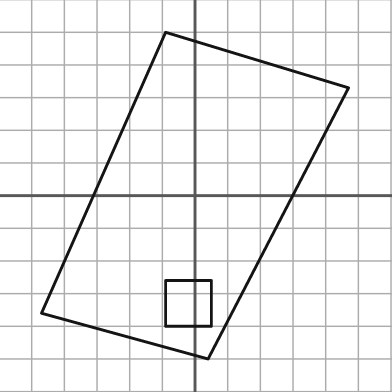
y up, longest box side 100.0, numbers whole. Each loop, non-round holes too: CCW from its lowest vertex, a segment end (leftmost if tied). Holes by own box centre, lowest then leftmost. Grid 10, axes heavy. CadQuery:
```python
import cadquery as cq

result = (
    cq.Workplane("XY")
    .moveTo(4.0, -50.0)
    .lineTo(47.0, 33.0)
    .lineTo(-9.0, 50.0)
    .lineTo(-47.0, -36.0)
    .close()
    .moveTo(-9.0, -40.0)
    .lineTo(5.0, -40.0)
    .lineTo(5.0, -26.0)
    .lineTo(-9.0, -26.0)
    .close()
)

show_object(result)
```